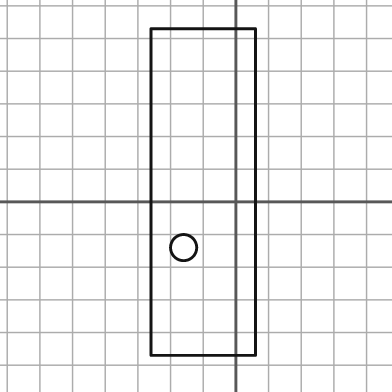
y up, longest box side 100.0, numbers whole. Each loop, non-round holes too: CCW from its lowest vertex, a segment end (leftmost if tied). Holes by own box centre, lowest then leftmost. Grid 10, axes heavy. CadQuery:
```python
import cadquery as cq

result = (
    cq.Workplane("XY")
    .moveTo(-26.0, -47.0)
    .lineTo(6.0, -47.0)
    .lineTo(6.0, 53.0)
    .lineTo(-26.0, 53.0)
    .close()
    .moveTo(-16.0, -14.0)
    .circle(4.0)
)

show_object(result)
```